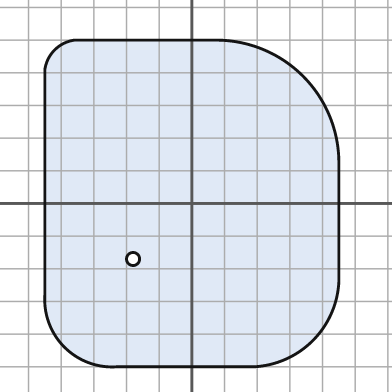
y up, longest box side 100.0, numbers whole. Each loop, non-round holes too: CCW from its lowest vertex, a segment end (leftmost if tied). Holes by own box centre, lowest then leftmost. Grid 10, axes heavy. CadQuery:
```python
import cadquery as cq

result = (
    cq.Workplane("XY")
    .moveTo(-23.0, -50.0)
    .lineTo(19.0, -50.0)
    .threePointArc((37.0, -42.0), (45.0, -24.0))
    .lineTo(45.0, 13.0)
    .threePointArc((34.0, 39.0), (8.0, 50.0))
    .lineTo(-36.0, 50.0)
    .threePointArc((-42.0, 47.0), (-45.0, 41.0))
    .lineTo(-45.0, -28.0)
    .threePointArc((-39.0, -44.0), (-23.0, -50.0))
    .close()
    .moveTo(-18.0, -17.0)
    .circle(2.0)
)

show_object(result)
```